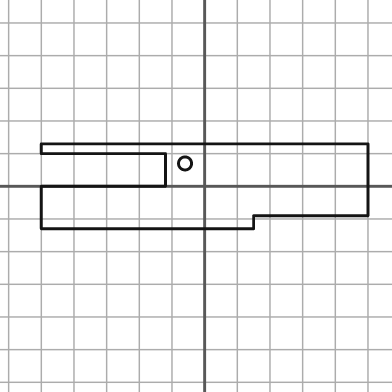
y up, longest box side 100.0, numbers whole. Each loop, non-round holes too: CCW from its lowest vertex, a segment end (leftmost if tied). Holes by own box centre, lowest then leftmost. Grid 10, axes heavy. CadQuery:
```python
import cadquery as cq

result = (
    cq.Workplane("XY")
    .moveTo(-50.0, -13.0)
    .lineTo(15.0, -13.0)
    .lineTo(15.0, -9.0)
    .lineTo(50.0, -9.0)
    .lineTo(50.0, 13.0)
    .lineTo(-50.0, 13.0)
    .lineTo(-50.0, 10.0)
    .lineTo(-12.0, 10.0)
    .lineTo(-12.0, 0.0)
    .lineTo(-50.0, 0.0)
    .close()
    .moveTo(-6.0, 7.0)
    .circle(2.0)
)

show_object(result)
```